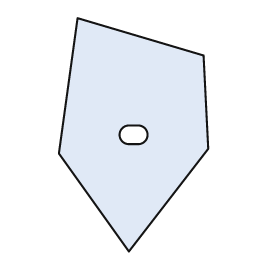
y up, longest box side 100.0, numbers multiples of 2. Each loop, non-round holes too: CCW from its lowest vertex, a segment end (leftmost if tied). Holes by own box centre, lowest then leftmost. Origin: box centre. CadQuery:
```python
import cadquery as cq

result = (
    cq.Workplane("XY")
    .moveTo(-2.0, -50.0)
    .lineTo(32.0, -6.0)
    .lineTo(30.0, 34.0)
    .lineTo(-24.0, 50.0)
    .lineTo(-32.0, -8.0)
    .close()
    .moveTo(-2.0, -4.0)
    .lineTo(2.0, -4.0)
    .threePointArc((6.0, 0.0), (2.0, 4.0))
    .lineTo(-2.0, 4.0)
    .threePointArc((-6.0, 0.0), (-2.0, -4.0))
    .close()
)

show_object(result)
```